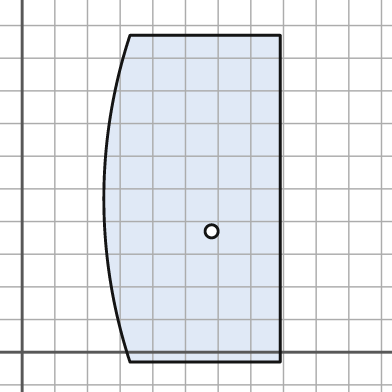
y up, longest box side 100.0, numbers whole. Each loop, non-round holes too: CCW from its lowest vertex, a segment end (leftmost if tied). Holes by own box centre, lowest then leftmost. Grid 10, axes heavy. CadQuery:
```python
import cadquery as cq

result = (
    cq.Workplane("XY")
    .moveTo(33.0, -3.0)
    .lineTo(79.0, -3.0)
    .lineTo(79.0, 97.0)
    .lineTo(33.0, 97.0)
    .threePointArc((25.0, 47.0), (33.0, -3.0))
    .close()
    .moveTo(58.0, 37.0)
    .circle(2.0)
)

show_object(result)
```